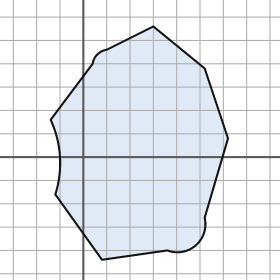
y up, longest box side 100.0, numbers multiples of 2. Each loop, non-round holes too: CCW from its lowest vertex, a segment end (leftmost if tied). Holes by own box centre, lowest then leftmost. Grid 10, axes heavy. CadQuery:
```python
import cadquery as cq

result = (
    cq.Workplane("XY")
    .moveTo(8.0, -44.0)
    .lineTo(36.0, -40.0)
    .threePointArc((48.0, -38.0), (52.0, -26.0))
    .lineTo(62.0, 8.0)
    .lineTo(52.0, 38.0)
    .lineTo(30.0, 56.0)
    .lineTo(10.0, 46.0)
    .threePointArc((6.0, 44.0), (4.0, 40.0))
    .lineTo(-14.0, 16.0)
    .threePointArc((-10.0, 0.0), (-12.0, -16.0))
    .close()
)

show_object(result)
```